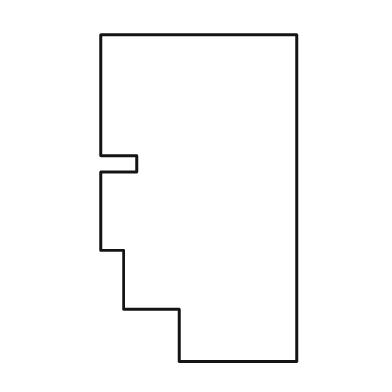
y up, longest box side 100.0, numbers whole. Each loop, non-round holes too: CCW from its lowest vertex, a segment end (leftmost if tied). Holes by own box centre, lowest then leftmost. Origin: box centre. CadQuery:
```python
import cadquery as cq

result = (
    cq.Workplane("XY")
    .moveTo(-6.0, -50.0)
    .lineTo(30.0, -50.0)
    .lineTo(30.0, 50.0)
    .lineTo(-30.0, 50.0)
    .lineTo(-30.0, 13.0)
    .lineTo(-19.0, 13.0)
    .lineTo(-19.0, 8.0)
    .lineTo(-30.0, 8.0)
    .lineTo(-30.0, -16.0)
    .lineTo(-23.0, -16.0)
    .lineTo(-23.0, -34.0)
    .lineTo(-6.0, -34.0)
    .close()
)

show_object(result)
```